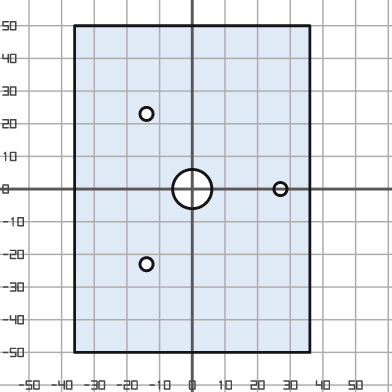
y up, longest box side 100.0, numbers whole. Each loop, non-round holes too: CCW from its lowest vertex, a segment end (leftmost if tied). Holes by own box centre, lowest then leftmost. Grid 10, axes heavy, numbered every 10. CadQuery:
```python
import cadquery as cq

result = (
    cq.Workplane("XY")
    .moveTo(-36.0, -50.0)
    .lineTo(36.0, -50.0)
    .lineTo(36.0, 50.0)
    .lineTo(-36.0, 50.0)
    .close()
    .moveTo(-14.0, -23.0)
    .circle(2.0)
    .moveTo(0.0, 0.0)
    .circle(6.0)
    .moveTo(27.0, 0.0)
    .circle(2.0)
    .moveTo(-14.0, 23.0)
    .circle(2.0)
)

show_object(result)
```